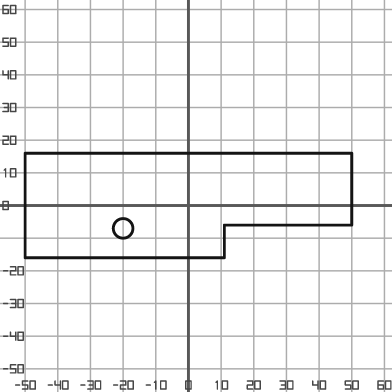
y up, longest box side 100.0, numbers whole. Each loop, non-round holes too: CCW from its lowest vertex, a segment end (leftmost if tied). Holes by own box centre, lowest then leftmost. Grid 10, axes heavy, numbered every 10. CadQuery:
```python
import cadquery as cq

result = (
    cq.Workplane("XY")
    .moveTo(-50.0, -16.0)
    .lineTo(11.0, -16.0)
    .lineTo(11.0, -6.0)
    .lineTo(50.0, -6.0)
    .lineTo(50.0, 16.0)
    .lineTo(-50.0, 16.0)
    .close()
    .moveTo(-20.0, -7.0)
    .circle(3.0)
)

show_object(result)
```